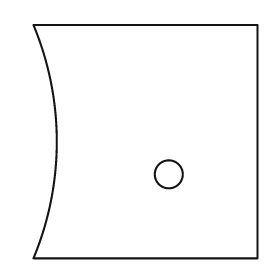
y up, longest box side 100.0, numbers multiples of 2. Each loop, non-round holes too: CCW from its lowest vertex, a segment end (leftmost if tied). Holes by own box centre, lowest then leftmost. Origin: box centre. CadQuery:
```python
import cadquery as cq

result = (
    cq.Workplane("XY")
    .moveTo(-48.0, -50.0)
    .lineTo(48.0, -50.0)
    .lineTo(48.0, 50.0)
    .lineTo(-48.0, 50.0)
    .threePointArc((-38.0, 0.0), (-48.0, -50.0))
    .close()
    .moveTo(10.0, -14.0)
    .circle(6.0)
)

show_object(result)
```